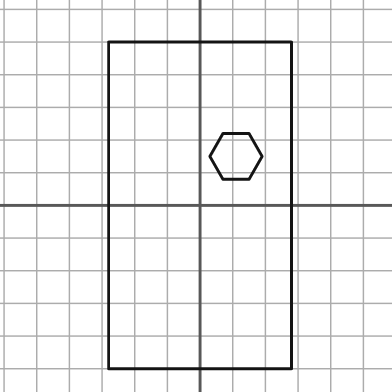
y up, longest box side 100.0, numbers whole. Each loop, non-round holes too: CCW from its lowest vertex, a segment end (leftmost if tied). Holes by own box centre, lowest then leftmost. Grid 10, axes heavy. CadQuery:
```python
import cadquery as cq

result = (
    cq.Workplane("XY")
    .moveTo(-28.0, -50.0)
    .lineTo(28.0, -50.0)
    .lineTo(28.0, 50.0)
    .lineTo(-28.0, 50.0)
    .close()
    .moveTo(7.0, 8.0)
    .lineTo(15.0, 8.0)
    .lineTo(19.0, 15.0)
    .lineTo(15.0, 22.0)
    .lineTo(7.0, 22.0)
    .lineTo(3.0, 15.0)
    .close()
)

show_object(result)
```